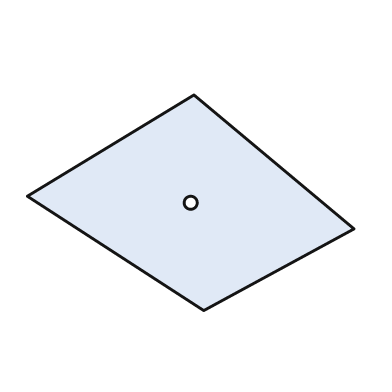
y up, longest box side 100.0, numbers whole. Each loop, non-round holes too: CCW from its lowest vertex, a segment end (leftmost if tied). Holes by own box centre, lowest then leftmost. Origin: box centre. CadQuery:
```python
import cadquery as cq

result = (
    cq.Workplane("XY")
    .moveTo(4.0, -33.0)
    .lineTo(50.0, -8.0)
    .lineTo(1.0, 33.0)
    .lineTo(-50.0, 2.0)
    .close()
    .moveTo(0.0, 0.0)
    .circle(2.0)
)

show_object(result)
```